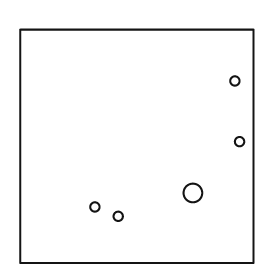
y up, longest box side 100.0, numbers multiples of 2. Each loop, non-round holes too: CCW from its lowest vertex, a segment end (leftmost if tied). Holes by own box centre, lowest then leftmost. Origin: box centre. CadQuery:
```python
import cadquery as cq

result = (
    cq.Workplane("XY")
    .moveTo(-50.0, -50.0)
    .lineTo(50.0, -50.0)
    .lineTo(50.0, 50.0)
    .lineTo(-50.0, 50.0)
    .close()
    .moveTo(-8.0, -30.0)
    .circle(2.0)
    .moveTo(-18.0, -26.0)
    .circle(2.0)
    .moveTo(24.0, -20.0)
    .circle(4.0)
    .moveTo(44.0, 2.0)
    .circle(2.0)
    .moveTo(42.0, 28.0)
    .circle(2.0)
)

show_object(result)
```